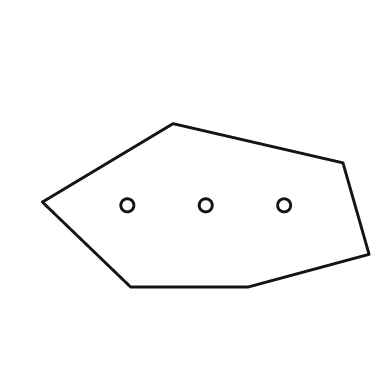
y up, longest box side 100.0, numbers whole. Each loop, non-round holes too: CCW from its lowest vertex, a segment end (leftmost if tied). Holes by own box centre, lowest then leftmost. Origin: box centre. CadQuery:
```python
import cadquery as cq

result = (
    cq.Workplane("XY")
    .moveTo(-23.0, -25.0)
    .lineTo(13.0, -25.0)
    .lineTo(50.0, -15.0)
    .lineTo(42.0, 13.0)
    .lineTo(-10.0, 25.0)
    .lineTo(-50.0, 1.0)
    .close()
    .moveTo(-24.0, 0.0)
    .circle(2.0)
    .moveTo(0.0, 0.0)
    .circle(2.0)
    .moveTo(24.0, 0.0)
    .circle(2.0)
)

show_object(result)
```